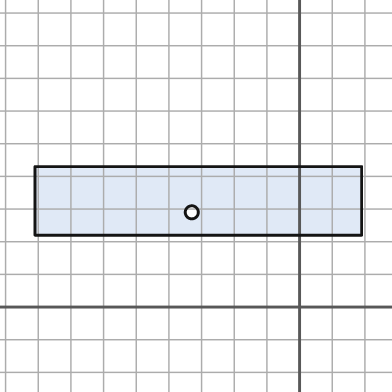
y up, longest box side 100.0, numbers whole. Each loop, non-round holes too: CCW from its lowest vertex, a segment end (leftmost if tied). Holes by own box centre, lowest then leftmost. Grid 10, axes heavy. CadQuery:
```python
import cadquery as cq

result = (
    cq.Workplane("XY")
    .moveTo(-81.0, 22.0)
    .lineTo(19.0, 22.0)
    .lineTo(19.0, 43.0)
    .lineTo(-81.0, 43.0)
    .close()
    .moveTo(-33.0, 29.0)
    .circle(2.0)
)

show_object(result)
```